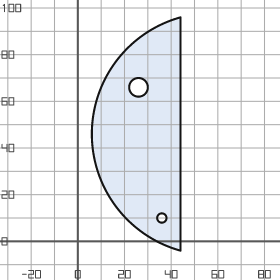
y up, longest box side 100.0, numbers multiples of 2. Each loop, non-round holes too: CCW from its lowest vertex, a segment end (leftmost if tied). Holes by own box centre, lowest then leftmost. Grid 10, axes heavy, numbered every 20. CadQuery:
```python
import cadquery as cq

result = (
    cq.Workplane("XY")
    .moveTo(44.0, -4.0)
    .lineTo(44.0, 96.0)
    .threePointArc((6.0, 46.0), (44.0, -4.0))
    .close()
    .moveTo(36.0, 10.0)
    .circle(2.0)
    .moveTo(26.0, 66.0)
    .circle(4.0)
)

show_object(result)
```